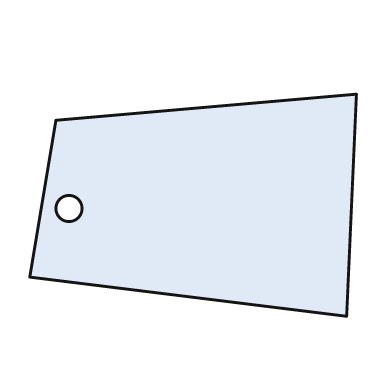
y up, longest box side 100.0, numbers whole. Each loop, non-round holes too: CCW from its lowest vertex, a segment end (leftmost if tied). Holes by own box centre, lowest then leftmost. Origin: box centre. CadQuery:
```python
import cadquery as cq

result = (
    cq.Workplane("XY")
    .moveTo(47.0, -34.0)
    .lineTo(50.0, 34.0)
    .lineTo(-42.0, 26.0)
    .lineTo(-50.0, -22.0)
    .close()
    .moveTo(-38.0, -1.0)
    .circle(4.0)
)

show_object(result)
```